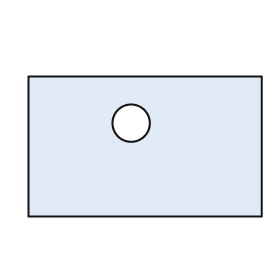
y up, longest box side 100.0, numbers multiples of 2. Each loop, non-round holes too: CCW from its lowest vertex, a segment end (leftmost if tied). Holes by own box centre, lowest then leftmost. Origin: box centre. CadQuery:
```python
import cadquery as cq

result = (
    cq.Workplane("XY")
    .moveTo(-50.0, -30.0)
    .lineTo(50.0, -30.0)
    .lineTo(50.0, 30.0)
    .lineTo(-50.0, 30.0)
    .close()
    .moveTo(-6.0, 10.0)
    .circle(8.0)
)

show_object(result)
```